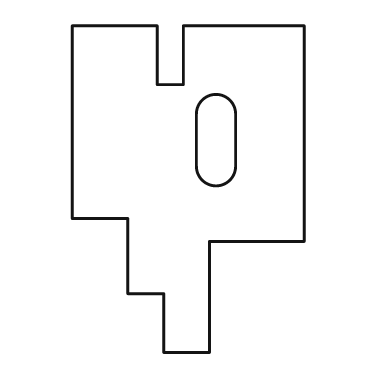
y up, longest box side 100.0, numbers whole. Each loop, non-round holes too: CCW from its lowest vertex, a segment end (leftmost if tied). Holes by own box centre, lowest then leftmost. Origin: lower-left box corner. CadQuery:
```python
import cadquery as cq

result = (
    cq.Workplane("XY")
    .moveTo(28.0, 0.0)
    .lineTo(42.0, 0.0)
    .lineTo(42.0, 34.0)
    .lineTo(71.0, 34.0)
    .lineTo(71.0, 100.0)
    .lineTo(34.0, 100.0)
    .lineTo(34.0, 82.0)
    .lineTo(26.0, 82.0)
    .lineTo(26.0, 100.0)
    .lineTo(0.0, 100.0)
    .lineTo(0.0, 41.0)
    .lineTo(17.0, 41.0)
    .lineTo(17.0, 18.0)
    .lineTo(28.0, 18.0)
    .close()
    .moveTo(38.0, 57.0)
    .threePointArc((44.0, 51.0), (50.0, 57.0))
    .lineTo(50.0, 73.0)
    .threePointArc((44.0, 79.0), (38.0, 73.0))
    .close()
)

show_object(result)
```